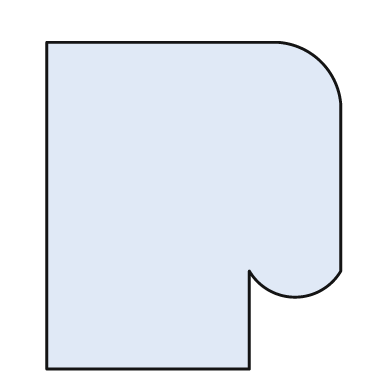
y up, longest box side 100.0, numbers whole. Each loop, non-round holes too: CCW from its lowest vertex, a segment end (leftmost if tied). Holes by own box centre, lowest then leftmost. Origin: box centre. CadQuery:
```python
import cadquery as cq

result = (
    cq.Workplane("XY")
    .moveTo(-45.0, -50.0)
    .lineTo(17.0, -50.0)
    .lineTo(17.0, -20.0)
    .threePointArc((31.0, -28.0), (45.0, -20.0))
    .lineTo(45.0, 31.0)
    .threePointArc((39.0, 44.0), (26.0, 50.0))
    .lineTo(-45.0, 50.0)
    .close()
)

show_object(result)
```